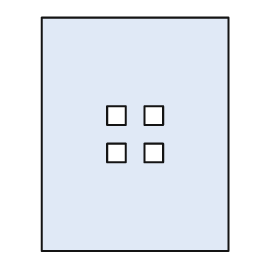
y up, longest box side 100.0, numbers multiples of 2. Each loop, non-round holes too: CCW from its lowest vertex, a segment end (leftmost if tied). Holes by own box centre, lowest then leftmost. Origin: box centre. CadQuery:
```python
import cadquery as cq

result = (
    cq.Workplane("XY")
    .moveTo(-40.0, -50.0)
    .lineTo(40.0, -50.0)
    .lineTo(40.0, 50.0)
    .lineTo(-40.0, 50.0)
    .close()
    .moveTo(-12.0, -12.0)
    .lineTo(-4.0, -12.0)
    .lineTo(-4.0, -4.0)
    .lineTo(-12.0, -4.0)
    .close()
    .moveTo(4.0, -12.0)
    .lineTo(12.0, -12.0)
    .lineTo(12.0, -4.0)
    .lineTo(4.0, -4.0)
    .close()
    .moveTo(-12.0, 4.0)
    .lineTo(-4.0, 4.0)
    .lineTo(-4.0, 12.0)
    .lineTo(-12.0, 12.0)
    .close()
    .moveTo(4.0, 4.0)
    .lineTo(12.0, 4.0)
    .lineTo(12.0, 12.0)
    .lineTo(4.0, 12.0)
    .close()
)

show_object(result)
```